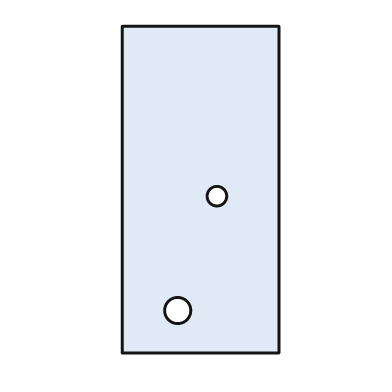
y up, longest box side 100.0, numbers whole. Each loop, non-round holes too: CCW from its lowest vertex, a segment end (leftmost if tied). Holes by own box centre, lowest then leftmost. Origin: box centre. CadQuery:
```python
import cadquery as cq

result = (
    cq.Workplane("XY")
    .moveTo(-24.0, -50.0)
    .lineTo(24.0, -50.0)
    .lineTo(24.0, 50.0)
    .lineTo(-24.0, 50.0)
    .close()
    .moveTo(-7.0, -37.0)
    .circle(4.0)
    .moveTo(5.0, -2.0)
    .circle(3.0)
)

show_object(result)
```